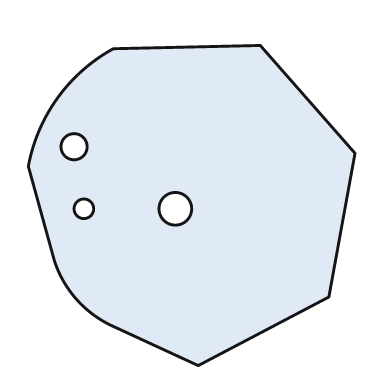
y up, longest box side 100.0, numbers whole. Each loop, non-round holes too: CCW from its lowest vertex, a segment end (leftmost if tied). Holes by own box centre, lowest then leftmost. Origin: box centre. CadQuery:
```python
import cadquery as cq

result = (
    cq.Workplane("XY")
    .moveTo(2.0, -49.0)
    .lineTo(42.0, -28.0)
    .lineTo(50.0, 16.0)
    .lineTo(21.0, 49.0)
    .lineTo(-24.0, 48.0)
    .threePointArc((-41.0, 33.0), (-50.0, 12.0))
    .lineTo(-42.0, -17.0)
    .threePointArc((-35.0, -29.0), (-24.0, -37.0))
    .close()
    .moveTo(-33.0, -1.0)
    .circle(3.0)
    .moveTo(-5.0, -1.0)
    .circle(5.0)
    .moveTo(-36.0, 18.0)
    .circle(4.0)
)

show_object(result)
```